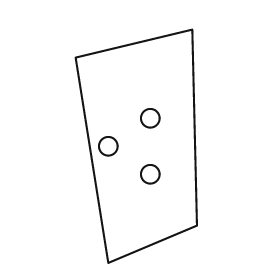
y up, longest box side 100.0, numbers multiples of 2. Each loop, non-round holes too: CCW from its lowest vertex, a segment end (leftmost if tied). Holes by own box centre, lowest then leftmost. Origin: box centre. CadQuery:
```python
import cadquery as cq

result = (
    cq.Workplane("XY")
    .moveTo(-12.0, -50.0)
    .lineTo(26.0, -34.0)
    .lineTo(24.0, 50.0)
    .lineTo(-26.0, 38.0)
    .close()
    .moveTo(6.0, -12.0)
    .circle(4.0)
    .moveTo(-12.0, 0.0)
    .circle(4.0)
    .moveTo(6.0, 12.0)
    .circle(4.0)
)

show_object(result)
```